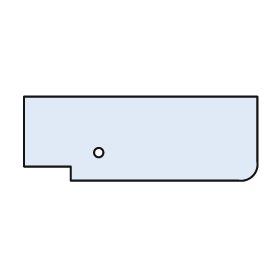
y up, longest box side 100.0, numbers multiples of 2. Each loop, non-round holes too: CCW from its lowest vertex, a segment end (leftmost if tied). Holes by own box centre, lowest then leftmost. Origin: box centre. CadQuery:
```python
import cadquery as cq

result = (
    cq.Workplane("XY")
    .moveTo(-30.0, -18.0)
    .lineTo(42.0, -18.0)
    .threePointArc((48.0, -16.0), (50.0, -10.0))
    .lineTo(50.0, 18.0)
    .lineTo(-50.0, 18.0)
    .lineTo(-50.0, -12.0)
    .lineTo(-30.0, -12.0)
    .close()
    .moveTo(-18.0, -6.0)
    .circle(2.0)
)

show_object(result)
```